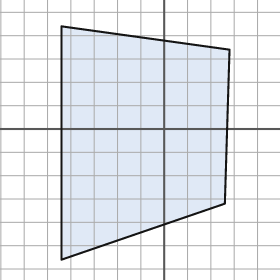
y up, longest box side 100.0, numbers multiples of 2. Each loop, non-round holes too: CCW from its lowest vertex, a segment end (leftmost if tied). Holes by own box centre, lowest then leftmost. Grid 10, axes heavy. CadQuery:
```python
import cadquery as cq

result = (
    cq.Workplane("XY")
    .moveTo(-44.0, -56.0)
    .lineTo(26.0, -32.0)
    .lineTo(28.0, 34.0)
    .lineTo(-44.0, 44.0)
    .close()
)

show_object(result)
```